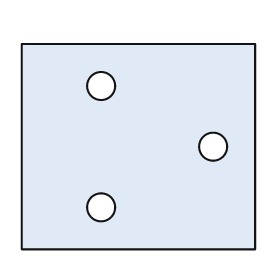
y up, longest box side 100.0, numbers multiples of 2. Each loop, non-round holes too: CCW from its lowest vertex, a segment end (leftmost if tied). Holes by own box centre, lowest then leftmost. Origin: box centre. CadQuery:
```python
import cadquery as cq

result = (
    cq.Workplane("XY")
    .moveTo(-50.0, -44.0)
    .lineTo(50.0, -44.0)
    .lineTo(50.0, 44.0)
    .lineTo(-50.0, 44.0)
    .close()
    .moveTo(-16.0, -26.0)
    .circle(6.0)
    .moveTo(32.0, 0.0)
    .circle(6.0)
    .moveTo(-16.0, 26.0)
    .circle(6.0)
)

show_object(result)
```